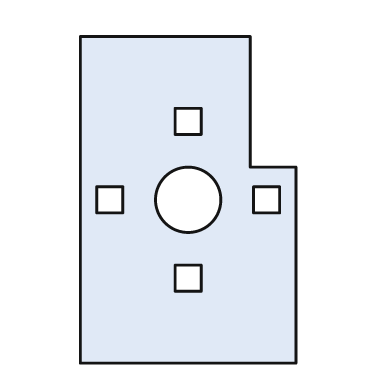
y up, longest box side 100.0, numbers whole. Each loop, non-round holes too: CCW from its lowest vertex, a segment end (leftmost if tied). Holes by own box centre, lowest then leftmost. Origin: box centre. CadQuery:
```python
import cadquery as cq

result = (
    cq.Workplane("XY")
    .moveTo(-33.0, -50.0)
    .lineTo(33.0, -50.0)
    .lineTo(33.0, 10.0)
    .lineTo(19.0, 10.0)
    .lineTo(19.0, 50.0)
    .lineTo(-33.0, 50.0)
    .close()
    .moveTo(-4.0, -28.0)
    .lineTo(4.0, -28.0)
    .lineTo(4.0, -20.0)
    .lineTo(-4.0, -20.0)
    .close()
    .moveTo(-28.0, -4.0)
    .lineTo(-20.0, -4.0)
    .lineTo(-20.0, 4.0)
    .lineTo(-28.0, 4.0)
    .close()
    .moveTo(0.0, 0.0)
    .circle(10.0)
    .moveTo(20.0, -4.0)
    .lineTo(28.0, -4.0)
    .lineTo(28.0, 4.0)
    .lineTo(20.0, 4.0)
    .close()
    .moveTo(-4.0, 20.0)
    .lineTo(4.0, 20.0)
    .lineTo(4.0, 28.0)
    .lineTo(-4.0, 28.0)
    .close()
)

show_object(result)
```